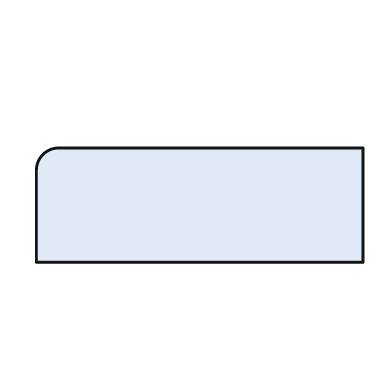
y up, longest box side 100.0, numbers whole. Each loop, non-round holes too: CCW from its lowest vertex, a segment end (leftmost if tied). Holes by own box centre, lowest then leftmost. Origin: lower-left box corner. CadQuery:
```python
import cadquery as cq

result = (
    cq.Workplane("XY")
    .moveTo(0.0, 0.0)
    .lineTo(100.0, 0.0)
    .lineTo(100.0, 35.0)
    .lineTo(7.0, 35.0)
    .threePointArc((2.0, 33.0), (0.0, 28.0))
    .close()
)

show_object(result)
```